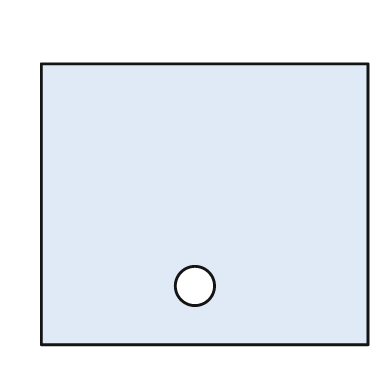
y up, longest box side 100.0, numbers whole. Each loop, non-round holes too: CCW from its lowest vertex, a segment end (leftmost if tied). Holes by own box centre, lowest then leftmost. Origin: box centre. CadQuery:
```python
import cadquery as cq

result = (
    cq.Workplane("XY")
    .moveTo(-50.0, -43.0)
    .lineTo(50.0, -43.0)
    .lineTo(50.0, 43.0)
    .lineTo(-50.0, 43.0)
    .close()
    .moveTo(-3.0, -25.0)
    .circle(6.0)
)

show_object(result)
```